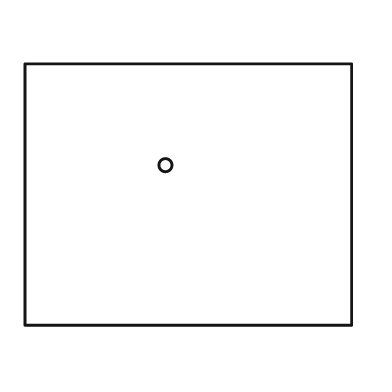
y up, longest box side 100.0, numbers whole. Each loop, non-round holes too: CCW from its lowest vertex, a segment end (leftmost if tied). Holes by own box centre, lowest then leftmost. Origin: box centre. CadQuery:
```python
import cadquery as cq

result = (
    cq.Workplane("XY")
    .moveTo(-50.0, -40.0)
    .lineTo(50.0, -40.0)
    .lineTo(50.0, 40.0)
    .lineTo(-50.0, 40.0)
    .close()
    .moveTo(-7.0, 9.0)
    .circle(2.0)
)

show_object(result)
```